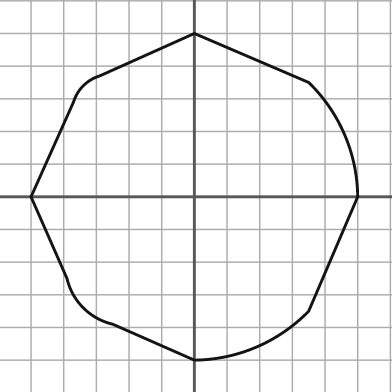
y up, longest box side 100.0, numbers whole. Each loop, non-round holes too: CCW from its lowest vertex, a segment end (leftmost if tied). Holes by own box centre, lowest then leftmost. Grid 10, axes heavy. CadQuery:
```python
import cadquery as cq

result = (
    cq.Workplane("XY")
    .moveTo(0.0, -50.0)
    .threePointArc((19.0, -46.0), (35.0, -35.0))
    .lineTo(50.0, 0.0)
    .threePointArc((46.0, 19.0), (35.0, 35.0))
    .lineTo(0.0, 50.0)
    .lineTo(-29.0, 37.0)
    .threePointArc((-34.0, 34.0), (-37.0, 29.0))
    .lineTo(-50.0, 0.0)
    .lineTo(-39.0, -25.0)
    .threePointArc((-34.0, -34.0), (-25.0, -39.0))
    .close()
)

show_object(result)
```